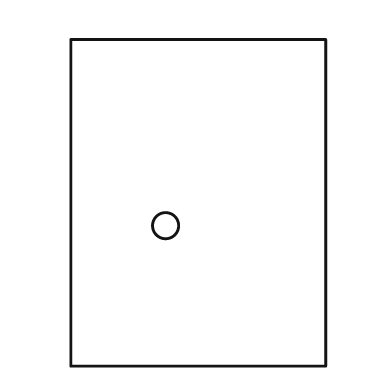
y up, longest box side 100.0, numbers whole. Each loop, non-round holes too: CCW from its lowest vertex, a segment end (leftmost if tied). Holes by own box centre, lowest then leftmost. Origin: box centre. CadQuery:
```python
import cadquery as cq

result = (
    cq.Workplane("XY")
    .moveTo(-39.0, -50.0)
    .lineTo(39.0, -50.0)
    .lineTo(39.0, 50.0)
    .lineTo(-39.0, 50.0)
    .close()
    .moveTo(-10.0, -7.0)
    .circle(4.0)
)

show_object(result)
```